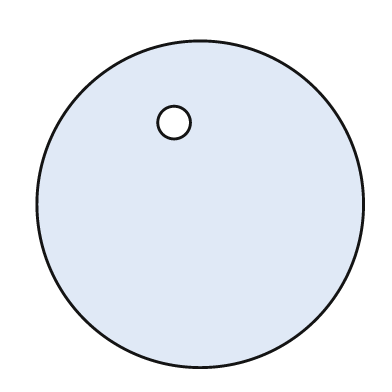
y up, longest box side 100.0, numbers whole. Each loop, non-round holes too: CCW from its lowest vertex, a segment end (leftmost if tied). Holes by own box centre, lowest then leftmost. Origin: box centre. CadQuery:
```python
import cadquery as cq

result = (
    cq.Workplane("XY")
    .moveTo(0.0, 0.0)
    .circle(50.0)
    .moveTo(-8.0, 25.0)
    .circle(5.0)
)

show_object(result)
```